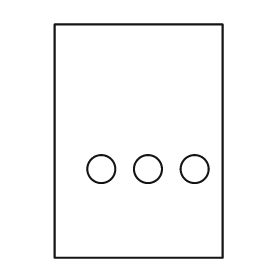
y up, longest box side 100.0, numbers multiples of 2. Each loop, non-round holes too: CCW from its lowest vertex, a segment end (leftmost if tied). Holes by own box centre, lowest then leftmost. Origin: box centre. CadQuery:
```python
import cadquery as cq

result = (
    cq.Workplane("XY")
    .moveTo(-36.0, -50.0)
    .lineTo(36.0, -50.0)
    .lineTo(36.0, 50.0)
    .lineTo(-36.0, 50.0)
    .close()
    .moveTo(-16.0, -12.0)
    .circle(6.0)
    .moveTo(4.0, -12.0)
    .circle(6.0)
    .moveTo(24.0, -12.0)
    .circle(6.0)
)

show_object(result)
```